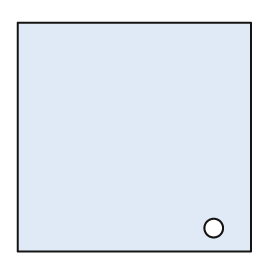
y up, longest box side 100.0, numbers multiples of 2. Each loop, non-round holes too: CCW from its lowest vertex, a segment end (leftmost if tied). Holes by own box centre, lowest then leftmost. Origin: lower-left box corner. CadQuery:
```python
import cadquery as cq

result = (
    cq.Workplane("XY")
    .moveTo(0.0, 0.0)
    .lineTo(100.0, 0.0)
    .lineTo(100.0, 98.0)
    .lineTo(0.0, 98.0)
    .close()
    .moveTo(84.0, 10.0)
    .circle(4.0)
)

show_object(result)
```